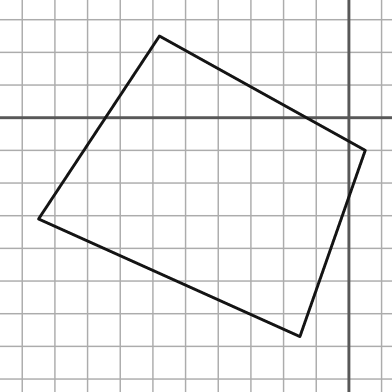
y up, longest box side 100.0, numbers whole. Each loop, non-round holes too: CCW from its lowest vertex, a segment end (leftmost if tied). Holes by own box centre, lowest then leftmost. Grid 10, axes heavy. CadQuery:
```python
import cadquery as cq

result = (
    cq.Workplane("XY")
    .moveTo(-15.0, -67.0)
    .lineTo(5.0, -10.0)
    .lineTo(-58.0, 25.0)
    .lineTo(-95.0, -31.0)
    .close()
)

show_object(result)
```